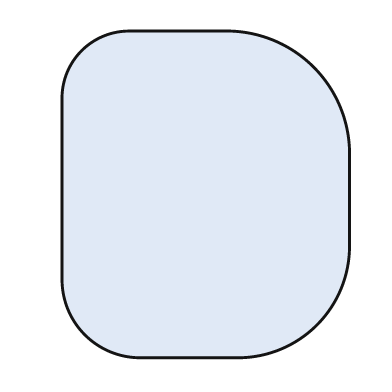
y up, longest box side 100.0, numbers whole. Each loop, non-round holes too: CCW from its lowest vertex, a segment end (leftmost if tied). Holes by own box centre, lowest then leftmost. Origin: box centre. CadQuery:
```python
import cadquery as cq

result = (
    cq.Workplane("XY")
    .moveTo(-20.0, -50.0)
    .lineTo(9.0, -50.0)
    .threePointArc((34.0, -40.0), (44.0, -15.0))
    .lineTo(44.0, 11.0)
    .threePointArc((33.0, 39.0), (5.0, 50.0))
    .lineTo(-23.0, 50.0)
    .threePointArc((-38.0, 44.0), (-44.0, 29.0))
    .lineTo(-44.0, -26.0)
    .threePointArc((-37.0, -43.0), (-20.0, -50.0))
    .close()
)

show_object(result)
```